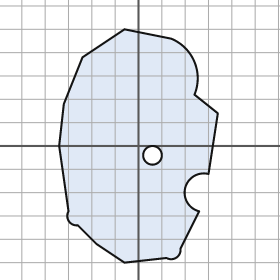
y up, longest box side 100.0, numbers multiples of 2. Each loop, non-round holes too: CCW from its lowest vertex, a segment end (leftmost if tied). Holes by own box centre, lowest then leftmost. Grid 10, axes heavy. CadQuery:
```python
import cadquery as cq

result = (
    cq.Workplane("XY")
    .moveTo(-6.0, -50.0)
    .lineTo(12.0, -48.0)
    .threePointArc((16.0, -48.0), (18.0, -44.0))
    .lineTo(26.0, -28.0)
    .threePointArc((20.0, -18.0), (30.0, -12.0))
    .lineTo(34.0, 14.0)
    .lineTo(24.0, 22.0)
    .threePointArc((24.0, 36.0), (14.0, 46.0))
    .lineTo(-6.0, 50.0)
    .lineTo(-24.0, 38.0)
    .lineTo(-32.0, 18.0)
    .lineTo(-34.0, 0.0)
    .lineTo(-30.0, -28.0)
    .threePointArc((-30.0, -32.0), (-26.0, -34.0))
    .lineTo(-18.0, -42.0)
    .close()
    .moveTo(6.0, -4.0)
    .circle(4.0)
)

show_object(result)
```